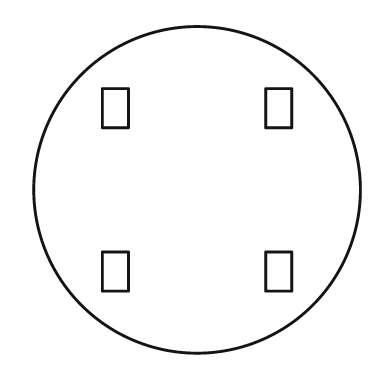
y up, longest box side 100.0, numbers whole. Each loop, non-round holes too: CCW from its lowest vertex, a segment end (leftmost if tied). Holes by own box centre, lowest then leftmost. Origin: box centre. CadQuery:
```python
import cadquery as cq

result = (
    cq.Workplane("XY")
    .moveTo(0.0, 0.0)
    .circle(50.0)
    .moveTo(-29.0, -31.0)
    .lineTo(-21.0, -31.0)
    .lineTo(-21.0, -19.0)
    .lineTo(-29.0, -19.0)
    .close()
    .moveTo(21.0, -31.0)
    .lineTo(29.0, -31.0)
    .lineTo(29.0, -19.0)
    .lineTo(21.0, -19.0)
    .close()
    .moveTo(-29.0, 19.0)
    .lineTo(-21.0, 19.0)
    .lineTo(-21.0, 31.0)
    .lineTo(-29.0, 31.0)
    .close()
    .moveTo(21.0, 19.0)
    .lineTo(29.0, 19.0)
    .lineTo(29.0, 31.0)
    .lineTo(21.0, 31.0)
    .close()
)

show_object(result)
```